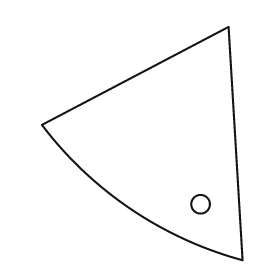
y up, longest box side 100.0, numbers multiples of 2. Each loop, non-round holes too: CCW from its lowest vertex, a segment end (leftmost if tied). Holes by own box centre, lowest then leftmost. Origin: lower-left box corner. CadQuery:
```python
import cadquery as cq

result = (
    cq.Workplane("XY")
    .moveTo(86.0, 0.0)
    .lineTo(80.0, 100.0)
    .lineTo(0.0, 58.0)
    .threePointArc((38.0, 22.0), (86.0, 0.0))
    .close()
    .moveTo(68.0, 24.0)
    .circle(4.0)
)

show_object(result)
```